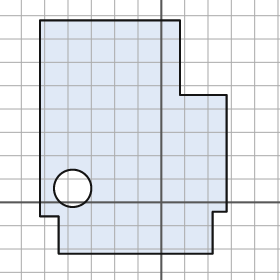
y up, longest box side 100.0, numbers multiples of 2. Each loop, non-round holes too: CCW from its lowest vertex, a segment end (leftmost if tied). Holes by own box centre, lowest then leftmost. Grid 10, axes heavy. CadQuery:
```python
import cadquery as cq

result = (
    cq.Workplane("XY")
    .moveTo(-44.0, -22.0)
    .lineTo(22.0, -22.0)
    .lineTo(22.0, -4.0)
    .lineTo(28.0, -4.0)
    .lineTo(28.0, 46.0)
    .lineTo(8.0, 46.0)
    .lineTo(8.0, 78.0)
    .lineTo(-52.0, 78.0)
    .lineTo(-52.0, -6.0)
    .lineTo(-44.0, -6.0)
    .close()
    .moveTo(-38.0, 6.0)
    .circle(8.0)
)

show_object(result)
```